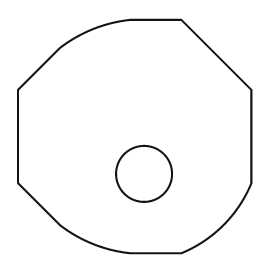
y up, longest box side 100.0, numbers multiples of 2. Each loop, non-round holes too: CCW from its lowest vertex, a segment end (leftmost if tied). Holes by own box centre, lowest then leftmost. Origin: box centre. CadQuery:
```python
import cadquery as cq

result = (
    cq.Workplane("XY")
    .moveTo(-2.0, -50.0)
    .lineTo(20.0, -50.0)
    .threePointArc((38.0, -38.0), (50.0, -20.0))
    .lineTo(50.0, 20.0)
    .lineTo(20.0, 50.0)
    .lineTo(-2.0, 50.0)
    .threePointArc((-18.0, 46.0), (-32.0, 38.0))
    .lineTo(-50.0, 20.0)
    .lineTo(-50.0, -20.0)
    .lineTo(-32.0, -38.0)
    .threePointArc((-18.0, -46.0), (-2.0, -50.0))
    .close()
    .moveTo(4.0, -16.0)
    .circle(12.0)
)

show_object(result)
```